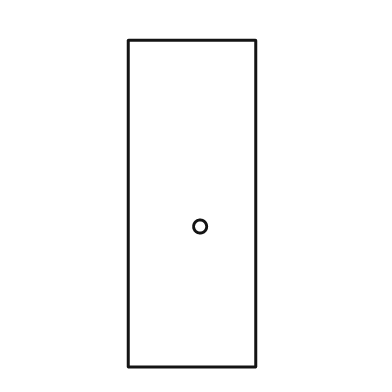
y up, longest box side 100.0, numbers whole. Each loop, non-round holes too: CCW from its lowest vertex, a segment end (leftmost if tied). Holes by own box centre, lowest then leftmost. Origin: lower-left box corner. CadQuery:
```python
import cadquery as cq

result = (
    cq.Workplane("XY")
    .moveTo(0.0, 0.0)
    .lineTo(39.0, 0.0)
    .lineTo(39.0, 100.0)
    .lineTo(0.0, 100.0)
    .close()
    .moveTo(22.0, 43.0)
    .circle(2.0)
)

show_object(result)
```